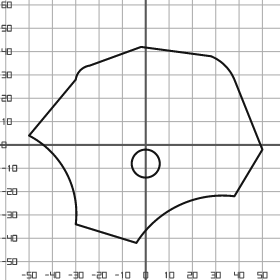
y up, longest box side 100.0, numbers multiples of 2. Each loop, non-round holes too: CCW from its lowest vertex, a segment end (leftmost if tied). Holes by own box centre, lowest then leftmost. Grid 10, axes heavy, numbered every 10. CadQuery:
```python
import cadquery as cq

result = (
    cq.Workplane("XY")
    .moveTo(-4.0, -42.0)
    .threePointArc((14.0, -26.0), (38.0, -22.0))
    .lineTo(50.0, -2.0)
    .lineTo(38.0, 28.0)
    .threePointArc((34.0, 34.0), (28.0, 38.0))
    .lineTo(-2.0, 42.0)
    .lineTo(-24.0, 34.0)
    .threePointArc((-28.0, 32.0), (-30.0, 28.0))
    .lineTo(-50.0, 4.0)
    .threePointArc((-34.0, -12.0), (-30.0, -34.0))
    .close()
    .moveTo(0.0, -8.0)
    .circle(6.0)
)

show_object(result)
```